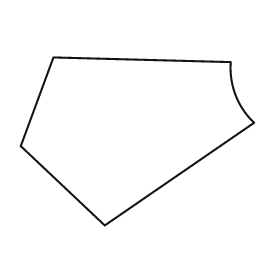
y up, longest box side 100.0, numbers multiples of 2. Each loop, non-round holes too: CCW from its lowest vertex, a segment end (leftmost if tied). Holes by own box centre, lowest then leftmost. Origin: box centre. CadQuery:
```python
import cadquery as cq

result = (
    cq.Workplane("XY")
    .moveTo(-14.0, -36.0)
    .lineTo(50.0, 8.0)
    .threePointArc((42.0, 20.0), (40.0, 34.0))
    .lineTo(-36.0, 36.0)
    .lineTo(-50.0, -2.0)
    .close()
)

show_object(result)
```